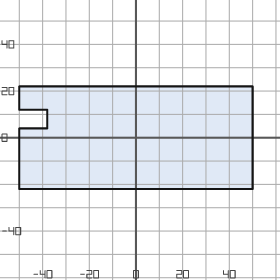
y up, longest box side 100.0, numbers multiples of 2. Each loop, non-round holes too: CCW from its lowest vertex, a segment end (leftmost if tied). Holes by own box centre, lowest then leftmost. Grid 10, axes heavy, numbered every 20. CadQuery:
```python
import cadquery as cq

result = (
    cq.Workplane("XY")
    .moveTo(-50.0, -22.0)
    .lineTo(50.0, -22.0)
    .lineTo(50.0, 22.0)
    .lineTo(-50.0, 22.0)
    .lineTo(-50.0, 12.0)
    .lineTo(-38.0, 12.0)
    .lineTo(-38.0, 4.0)
    .lineTo(-50.0, 4.0)
    .close()
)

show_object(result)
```